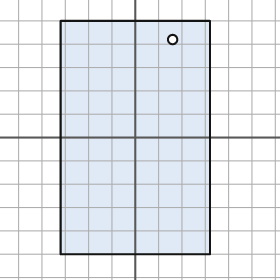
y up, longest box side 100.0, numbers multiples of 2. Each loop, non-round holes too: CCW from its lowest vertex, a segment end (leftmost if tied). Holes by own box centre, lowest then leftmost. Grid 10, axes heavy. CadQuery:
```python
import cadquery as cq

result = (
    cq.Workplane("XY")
    .moveTo(-32.0, -50.0)
    .lineTo(32.0, -50.0)
    .lineTo(32.0, 50.0)
    .lineTo(-32.0, 50.0)
    .close()
    .moveTo(16.0, 42.0)
    .circle(2.0)
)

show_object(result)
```